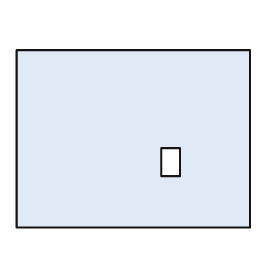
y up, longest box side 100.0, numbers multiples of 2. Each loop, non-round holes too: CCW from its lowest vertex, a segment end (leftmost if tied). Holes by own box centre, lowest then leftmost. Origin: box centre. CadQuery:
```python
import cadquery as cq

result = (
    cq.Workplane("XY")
    .moveTo(-50.0, -38.0)
    .lineTo(50.0, -38.0)
    .lineTo(50.0, 38.0)
    .lineTo(-50.0, 38.0)
    .close()
    .moveTo(12.0, -16.0)
    .lineTo(20.0, -16.0)
    .lineTo(20.0, -4.0)
    .lineTo(12.0, -4.0)
    .close()
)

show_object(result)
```